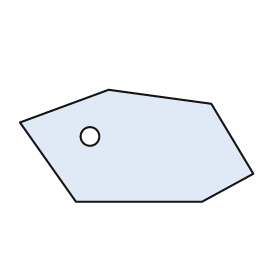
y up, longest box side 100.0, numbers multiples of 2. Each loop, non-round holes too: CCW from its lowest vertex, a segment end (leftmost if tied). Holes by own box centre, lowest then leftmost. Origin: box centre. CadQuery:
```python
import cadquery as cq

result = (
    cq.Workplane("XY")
    .moveTo(-26.0, -24.0)
    .lineTo(28.0, -24.0)
    .lineTo(50.0, -12.0)
    .lineTo(32.0, 18.0)
    .lineTo(-12.0, 24.0)
    .lineTo(-50.0, 10.0)
    .close()
    .moveTo(-20.0, 4.0)
    .circle(4.0)
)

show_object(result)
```